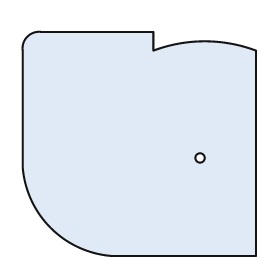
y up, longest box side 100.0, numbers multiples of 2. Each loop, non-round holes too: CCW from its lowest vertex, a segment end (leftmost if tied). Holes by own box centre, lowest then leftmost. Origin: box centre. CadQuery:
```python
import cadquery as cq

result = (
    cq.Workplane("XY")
    .moveTo(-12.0, -48.0)
    .lineTo(50.0, -48.0)
    .lineTo(50.0, 40.0)
    .threePointArc((28.0, 44.0), (6.0, 40.0))
    .lineTo(6.0, 48.0)
    .lineTo(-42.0, 48.0)
    .threePointArc((-48.0, 46.0), (-50.0, 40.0))
    .lineTo(-50.0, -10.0)
    .threePointArc((-38.0, -36.0), (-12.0, -48.0))
    .close()
    .moveTo(26.0, -6.0)
    .circle(2.0)
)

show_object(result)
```